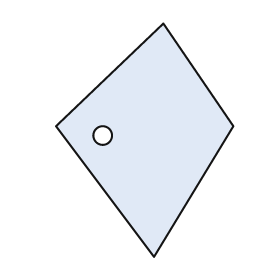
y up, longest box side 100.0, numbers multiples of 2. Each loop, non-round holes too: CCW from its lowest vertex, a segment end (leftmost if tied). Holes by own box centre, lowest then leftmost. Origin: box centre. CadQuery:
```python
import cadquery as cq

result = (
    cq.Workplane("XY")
    .moveTo(4.0, -50.0)
    .lineTo(38.0, 6.0)
    .lineTo(8.0, 50.0)
    .lineTo(-38.0, 6.0)
    .close()
    .moveTo(-18.0, 2.0)
    .circle(4.0)
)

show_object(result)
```